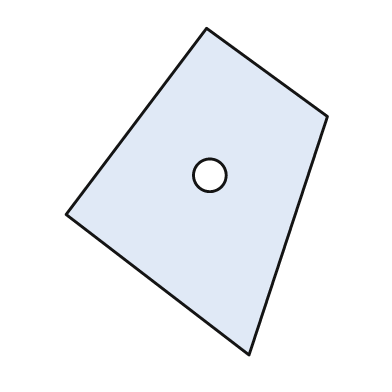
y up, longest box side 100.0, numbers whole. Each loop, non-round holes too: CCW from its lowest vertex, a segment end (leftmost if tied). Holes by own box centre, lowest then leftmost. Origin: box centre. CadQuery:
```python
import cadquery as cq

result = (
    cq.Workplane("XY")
    .moveTo(16.0, -50.0)
    .lineTo(40.0, 23.0)
    .lineTo(3.0, 50.0)
    .lineTo(-40.0, -7.0)
    .close()
    .moveTo(4.0, 5.0)
    .circle(5.0)
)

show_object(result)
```